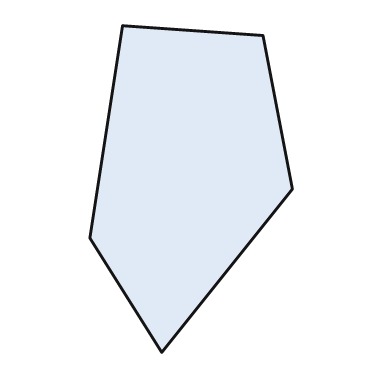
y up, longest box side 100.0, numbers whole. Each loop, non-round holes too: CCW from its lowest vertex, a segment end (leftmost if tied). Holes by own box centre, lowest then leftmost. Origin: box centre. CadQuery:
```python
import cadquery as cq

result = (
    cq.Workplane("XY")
    .moveTo(-9.0, -50.0)
    .lineTo(31.0, 0.0)
    .lineTo(22.0, 47.0)
    .lineTo(-21.0, 50.0)
    .lineTo(-31.0, -15.0)
    .close()
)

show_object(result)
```